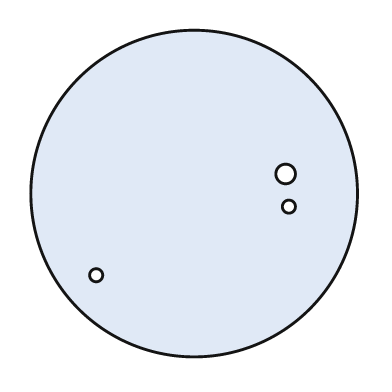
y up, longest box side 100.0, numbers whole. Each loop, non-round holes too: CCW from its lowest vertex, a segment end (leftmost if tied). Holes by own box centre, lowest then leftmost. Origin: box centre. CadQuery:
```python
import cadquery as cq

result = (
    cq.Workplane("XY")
    .moveTo(0.0, 0.0)
    .circle(50.0)
    .moveTo(-30.0, -25.0)
    .circle(2.0)
    .moveTo(29.0, -4.0)
    .circle(2.0)
    .moveTo(28.0, 6.0)
    .circle(3.0)
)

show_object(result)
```